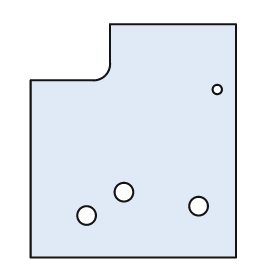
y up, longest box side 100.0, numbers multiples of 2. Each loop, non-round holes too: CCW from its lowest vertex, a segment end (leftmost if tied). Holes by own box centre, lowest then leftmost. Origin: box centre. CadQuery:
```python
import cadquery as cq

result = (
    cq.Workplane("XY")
    .moveTo(-44.0, -50.0)
    .lineTo(44.0, -50.0)
    .lineTo(44.0, 50.0)
    .lineTo(-10.0, 50.0)
    .lineTo(-10.0, 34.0)
    .threePointArc((-12.0, 28.0), (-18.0, 26.0))
    .lineTo(-44.0, 26.0)
    .close()
    .moveTo(-20.0, -32.0)
    .circle(4.0)
    .moveTo(28.0, -28.0)
    .circle(4.0)
    .moveTo(-4.0, -22.0)
    .circle(4.0)
    .moveTo(36.0, 22.0)
    .circle(2.0)
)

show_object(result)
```